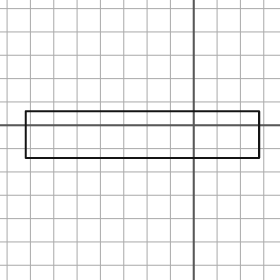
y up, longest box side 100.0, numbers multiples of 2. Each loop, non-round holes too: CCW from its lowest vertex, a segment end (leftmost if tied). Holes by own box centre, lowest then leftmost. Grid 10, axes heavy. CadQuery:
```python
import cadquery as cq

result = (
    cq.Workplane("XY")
    .moveTo(-72.0, -14.0)
    .lineTo(28.0, -14.0)
    .lineTo(28.0, 6.0)
    .lineTo(-72.0, 6.0)
    .close()
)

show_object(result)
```